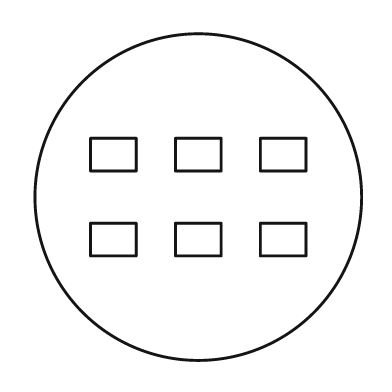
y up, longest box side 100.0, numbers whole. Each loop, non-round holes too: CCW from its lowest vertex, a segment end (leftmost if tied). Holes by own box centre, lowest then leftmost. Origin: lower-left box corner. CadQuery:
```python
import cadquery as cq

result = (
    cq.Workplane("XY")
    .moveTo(50.0, 50.0)
    .circle(50.0)
    .moveTo(17.0, 32.0)
    .lineTo(31.0, 32.0)
    .lineTo(31.0, 42.0)
    .lineTo(17.0, 42.0)
    .close()
    .moveTo(43.0, 32.0)
    .lineTo(57.0, 32.0)
    .lineTo(57.0, 42.0)
    .lineTo(43.0, 42.0)
    .close()
    .moveTo(69.0, 32.0)
    .lineTo(83.0, 32.0)
    .lineTo(83.0, 42.0)
    .lineTo(69.0, 42.0)
    .close()
    .moveTo(17.0, 58.0)
    .lineTo(31.0, 58.0)
    .lineTo(31.0, 68.0)
    .lineTo(17.0, 68.0)
    .close()
    .moveTo(43.0, 58.0)
    .lineTo(57.0, 58.0)
    .lineTo(57.0, 68.0)
    .lineTo(43.0, 68.0)
    .close()
    .moveTo(69.0, 58.0)
    .lineTo(83.0, 58.0)
    .lineTo(83.0, 68.0)
    .lineTo(69.0, 68.0)
    .close()
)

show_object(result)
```